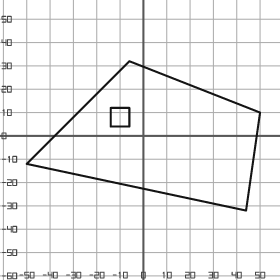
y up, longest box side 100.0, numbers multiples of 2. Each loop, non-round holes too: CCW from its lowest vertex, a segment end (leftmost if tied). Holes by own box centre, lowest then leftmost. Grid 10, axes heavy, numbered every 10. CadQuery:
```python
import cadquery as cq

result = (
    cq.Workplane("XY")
    .moveTo(44.0, -32.0)
    .lineTo(50.0, 10.0)
    .lineTo(-6.0, 32.0)
    .lineTo(-50.0, -12.0)
    .close()
    .moveTo(-14.0, 4.0)
    .lineTo(-6.0, 4.0)
    .lineTo(-6.0, 12.0)
    .lineTo(-14.0, 12.0)
    .close()
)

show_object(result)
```